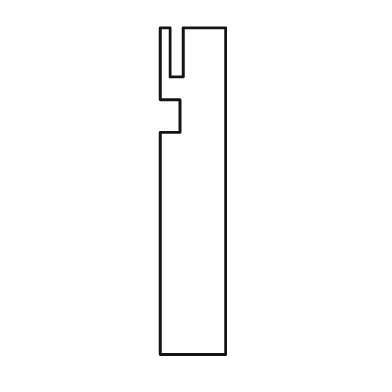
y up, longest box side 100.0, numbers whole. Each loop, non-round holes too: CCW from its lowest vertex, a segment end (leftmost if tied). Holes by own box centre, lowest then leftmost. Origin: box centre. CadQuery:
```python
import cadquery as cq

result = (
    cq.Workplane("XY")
    .moveTo(-10.0, -50.0)
    .lineTo(10.0, -50.0)
    .lineTo(10.0, 50.0)
    .lineTo(-3.0, 50.0)
    .lineTo(-3.0, 35.0)
    .lineTo(-7.0, 35.0)
    .lineTo(-7.0, 50.0)
    .lineTo(-10.0, 50.0)
    .lineTo(-10.0, 28.0)
    .lineTo(-4.0, 28.0)
    .lineTo(-4.0, 18.0)
    .lineTo(-10.0, 18.0)
    .close()
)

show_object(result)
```